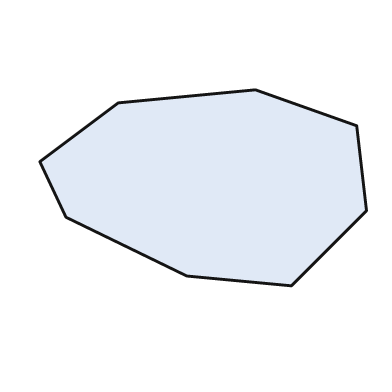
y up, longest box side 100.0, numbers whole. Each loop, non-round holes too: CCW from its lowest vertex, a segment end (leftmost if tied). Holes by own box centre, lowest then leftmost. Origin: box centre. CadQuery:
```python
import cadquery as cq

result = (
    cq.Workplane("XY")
    .moveTo(27.0, -30.0)
    .lineTo(50.0, -7.0)
    .lineTo(47.0, 19.0)
    .lineTo(16.0, 30.0)
    .lineTo(-26.0, 26.0)
    .lineTo(-50.0, 8.0)
    .lineTo(-42.0, -9.0)
    .lineTo(-5.0, -27.0)
    .close()
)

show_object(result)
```